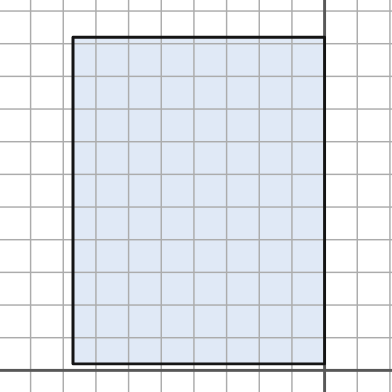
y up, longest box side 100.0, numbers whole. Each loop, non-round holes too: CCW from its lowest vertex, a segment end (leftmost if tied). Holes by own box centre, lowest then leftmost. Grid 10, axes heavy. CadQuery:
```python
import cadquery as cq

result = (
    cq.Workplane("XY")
    .moveTo(-77.0, 2.0)
    .lineTo(0.0, 2.0)
    .lineTo(0.0, 102.0)
    .lineTo(-77.0, 102.0)
    .close()
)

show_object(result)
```